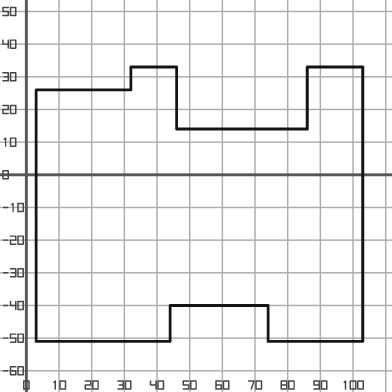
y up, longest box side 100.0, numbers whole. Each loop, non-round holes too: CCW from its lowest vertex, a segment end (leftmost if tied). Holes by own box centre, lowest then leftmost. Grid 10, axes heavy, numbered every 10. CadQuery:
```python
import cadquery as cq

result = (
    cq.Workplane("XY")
    .moveTo(3.0, -51.0)
    .lineTo(44.0, -51.0)
    .lineTo(44.0, -40.0)
    .lineTo(74.0, -40.0)
    .lineTo(74.0, -51.0)
    .lineTo(103.0, -51.0)
    .lineTo(103.0, 33.0)
    .lineTo(86.0, 33.0)
    .lineTo(86.0, 14.0)
    .lineTo(46.0, 14.0)
    .lineTo(46.0, 33.0)
    .lineTo(32.0, 33.0)
    .lineTo(32.0, 26.0)
    .lineTo(3.0, 26.0)
    .close()
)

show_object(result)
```